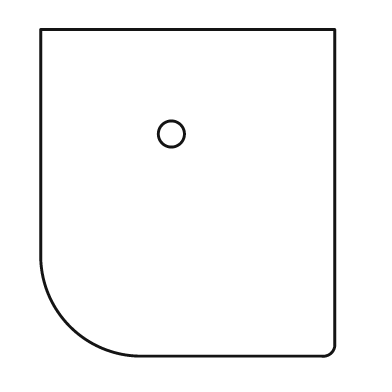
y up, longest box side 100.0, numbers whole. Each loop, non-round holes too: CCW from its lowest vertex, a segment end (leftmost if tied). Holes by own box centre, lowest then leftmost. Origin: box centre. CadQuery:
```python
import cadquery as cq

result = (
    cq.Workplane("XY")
    .moveTo(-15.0, -50.0)
    .lineTo(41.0, -50.0)
    .threePointArc((44.0, -49.0), (45.0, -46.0))
    .lineTo(45.0, 50.0)
    .lineTo(-45.0, 50.0)
    .lineTo(-45.0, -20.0)
    .threePointArc((-36.0, -41.0), (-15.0, -50.0))
    .close()
    .moveTo(-5.0, 18.0)
    .circle(4.0)
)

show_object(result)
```